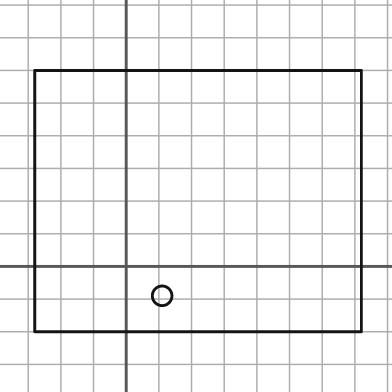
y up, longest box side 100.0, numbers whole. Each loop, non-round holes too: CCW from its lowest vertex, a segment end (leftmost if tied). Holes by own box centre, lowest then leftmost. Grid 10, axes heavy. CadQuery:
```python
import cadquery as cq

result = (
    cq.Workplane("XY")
    .moveTo(-28.0, -20.0)
    .lineTo(72.0, -20.0)
    .lineTo(72.0, 60.0)
    .lineTo(-28.0, 60.0)
    .close()
    .moveTo(11.0, -9.0)
    .circle(3.0)
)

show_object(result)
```